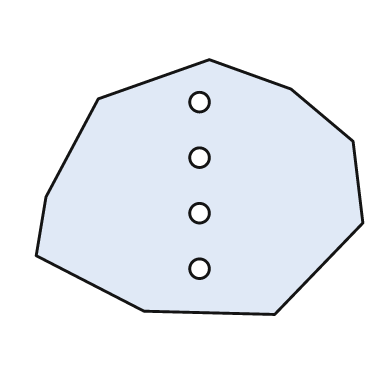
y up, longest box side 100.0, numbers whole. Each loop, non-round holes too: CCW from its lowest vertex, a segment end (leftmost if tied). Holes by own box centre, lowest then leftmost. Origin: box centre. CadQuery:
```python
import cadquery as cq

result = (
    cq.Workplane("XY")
    .moveTo(23.0, -39.0)
    .lineTo(50.0, -11.0)
    .lineTo(47.0, 14.0)
    .lineTo(28.0, 30.0)
    .lineTo(3.0, 39.0)
    .lineTo(-31.0, 27.0)
    .lineTo(-47.0, -3.0)
    .lineTo(-50.0, -21.0)
    .lineTo(-17.0, -38.0)
    .close()
    .moveTo(0.0, -25.0)
    .circle(3.0)
    .moveTo(0.0, -8.0)
    .circle(3.0)
    .moveTo(0.0, 9.0)
    .circle(3.0)
    .moveTo(0.0, 26.0)
    .circle(3.0)
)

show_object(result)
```